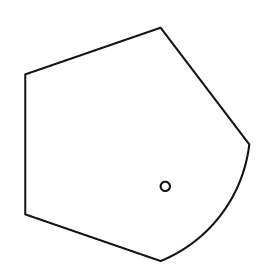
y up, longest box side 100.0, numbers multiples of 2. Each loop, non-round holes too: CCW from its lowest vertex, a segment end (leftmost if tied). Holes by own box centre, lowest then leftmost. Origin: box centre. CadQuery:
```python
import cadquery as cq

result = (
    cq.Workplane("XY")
    .moveTo(10.0, -50.0)
    .threePointArc((36.0, -30.0), (48.0, 0.0))
    .lineTo(10.0, 50.0)
    .lineTo(-48.0, 30.0)
    .lineTo(-48.0, -30.0)
    .close()
    .moveTo(12.0, -18.0)
    .circle(2.0)
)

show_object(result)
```